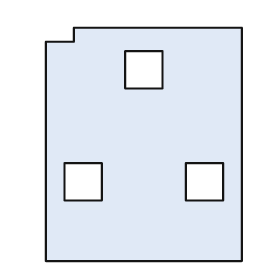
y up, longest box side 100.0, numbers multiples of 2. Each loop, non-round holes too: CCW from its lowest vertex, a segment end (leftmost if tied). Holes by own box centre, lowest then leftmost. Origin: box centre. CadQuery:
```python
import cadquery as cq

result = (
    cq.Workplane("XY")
    .moveTo(-42.0, -50.0)
    .lineTo(42.0, -50.0)
    .lineTo(42.0, 50.0)
    .lineTo(-30.0, 50.0)
    .lineTo(-30.0, 44.0)
    .lineTo(-42.0, 44.0)
    .close()
    .moveTo(-34.0, -24.0)
    .lineTo(-18.0, -24.0)
    .lineTo(-18.0, -8.0)
    .lineTo(-34.0, -8.0)
    .close()
    .moveTo(18.0, -24.0)
    .lineTo(34.0, -24.0)
    .lineTo(34.0, -8.0)
    .lineTo(18.0, -8.0)
    .close()
    .moveTo(-8.0, 24.0)
    .lineTo(8.0, 24.0)
    .lineTo(8.0, 40.0)
    .lineTo(-8.0, 40.0)
    .close()
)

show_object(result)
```